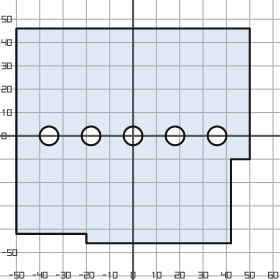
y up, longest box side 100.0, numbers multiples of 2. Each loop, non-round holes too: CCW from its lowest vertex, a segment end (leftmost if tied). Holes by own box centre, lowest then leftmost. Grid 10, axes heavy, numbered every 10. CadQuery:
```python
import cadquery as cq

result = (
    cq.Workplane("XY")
    .moveTo(-20.0, -46.0)
    .lineTo(42.0, -46.0)
    .lineTo(42.0, -10.0)
    .lineTo(50.0, -10.0)
    .lineTo(50.0, 46.0)
    .lineTo(-50.0, 46.0)
    .lineTo(-50.0, -42.0)
    .lineTo(-20.0, -42.0)
    .close()
    .moveTo(-36.0, 0.0)
    .circle(4.0)
    .moveTo(-18.0, 0.0)
    .circle(4.0)
    .moveTo(0.0, 0.0)
    .circle(4.0)
    .moveTo(18.0, 0.0)
    .circle(4.0)
    .moveTo(36.0, 0.0)
    .circle(4.0)
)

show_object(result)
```